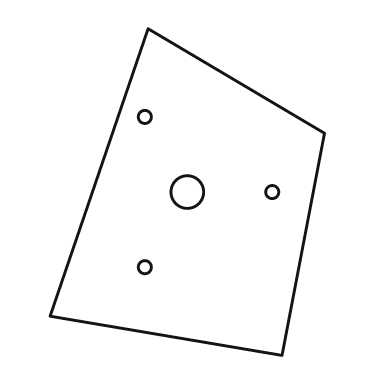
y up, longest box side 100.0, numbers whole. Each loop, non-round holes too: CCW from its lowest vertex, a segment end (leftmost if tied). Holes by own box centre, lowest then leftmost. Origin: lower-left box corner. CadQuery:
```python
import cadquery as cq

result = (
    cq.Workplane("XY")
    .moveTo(71.0, 0.0)
    .lineTo(84.0, 68.0)
    .lineTo(30.0, 100.0)
    .lineTo(0.0, 12.0)
    .close()
    .moveTo(29.0, 27.0)
    .circle(2.0)
    .moveTo(42.0, 50.0)
    .circle(5.0)
    .moveTo(68.0, 50.0)
    .circle(2.0)
    .moveTo(29.0, 73.0)
    .circle(2.0)
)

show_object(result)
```